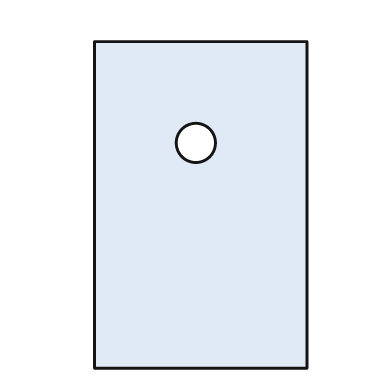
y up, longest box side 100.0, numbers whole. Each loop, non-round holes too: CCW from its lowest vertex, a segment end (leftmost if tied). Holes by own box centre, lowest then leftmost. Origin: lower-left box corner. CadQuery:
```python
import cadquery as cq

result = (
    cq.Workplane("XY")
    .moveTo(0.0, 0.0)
    .lineTo(65.0, 0.0)
    .lineTo(65.0, 100.0)
    .lineTo(0.0, 100.0)
    .close()
    .moveTo(31.0, 69.0)
    .circle(6.0)
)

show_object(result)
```